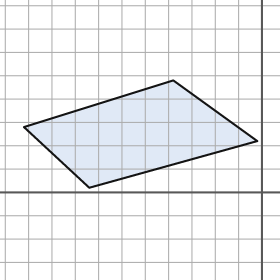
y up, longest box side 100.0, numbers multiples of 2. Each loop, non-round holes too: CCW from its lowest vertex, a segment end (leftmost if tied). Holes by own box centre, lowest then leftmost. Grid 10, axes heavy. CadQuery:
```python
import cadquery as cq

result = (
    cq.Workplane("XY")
    .moveTo(-74.0, 2.0)
    .lineTo(-2.0, 22.0)
    .lineTo(-38.0, 48.0)
    .lineTo(-102.0, 28.0)
    .close()
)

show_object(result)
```